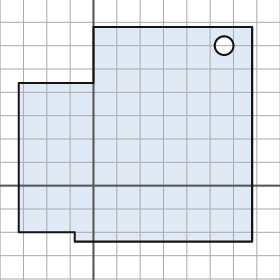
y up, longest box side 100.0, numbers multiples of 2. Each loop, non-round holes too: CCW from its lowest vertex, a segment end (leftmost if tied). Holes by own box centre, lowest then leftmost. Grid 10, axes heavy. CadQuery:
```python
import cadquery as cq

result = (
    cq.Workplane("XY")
    .moveTo(-8.0, -24.0)
    .lineTo(68.0, -24.0)
    .lineTo(68.0, 68.0)
    .lineTo(0.0, 68.0)
    .lineTo(0.0, 44.0)
    .lineTo(-32.0, 44.0)
    .lineTo(-32.0, -20.0)
    .lineTo(-8.0, -20.0)
    .close()
    .moveTo(56.0, 60.0)
    .circle(4.0)
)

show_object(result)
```